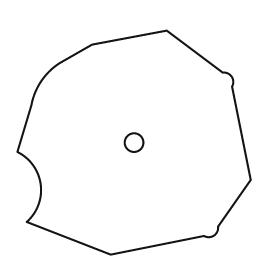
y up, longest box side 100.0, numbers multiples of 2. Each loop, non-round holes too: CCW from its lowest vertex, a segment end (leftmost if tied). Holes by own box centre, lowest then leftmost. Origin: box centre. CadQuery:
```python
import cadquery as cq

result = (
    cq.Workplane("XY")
    .moveTo(-10.0, -48.0)
    .lineTo(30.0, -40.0)
    .threePointArc((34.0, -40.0), (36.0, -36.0))
    .lineTo(50.0, -16.0)
    .lineTo(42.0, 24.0)
    .threePointArc((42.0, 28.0), (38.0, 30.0))
    .lineTo(14.0, 48.0)
    .lineTo(-18.0, 42.0)
    .lineTo(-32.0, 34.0)
    .threePointArc((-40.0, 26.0), (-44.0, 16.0))
    .lineTo(-50.0, -4.0)
    .threePointArc((-40.0, -18.0), (-46.0, -34.0))
    .close()
    .moveTo(0.0, 0.0)
    .circle(4.0)
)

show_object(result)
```